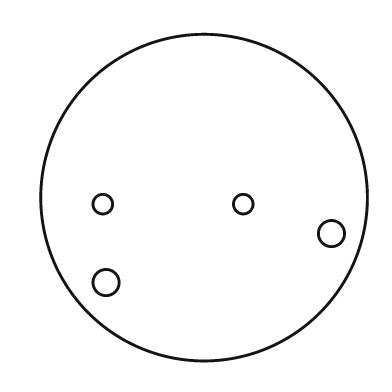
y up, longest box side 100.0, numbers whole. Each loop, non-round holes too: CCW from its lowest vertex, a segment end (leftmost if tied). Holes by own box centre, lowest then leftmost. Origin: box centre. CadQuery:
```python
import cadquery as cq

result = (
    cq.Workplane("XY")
    .moveTo(0.0, 0.0)
    .circle(50.0)
    .moveTo(-30.0, -26.0)
    .circle(4.0)
    .moveTo(39.0, -11.0)
    .circle(4.0)
    .moveTo(-31.0, -2.0)
    .circle(3.0)
    .moveTo(12.0, -2.0)
    .circle(3.0)
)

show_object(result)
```